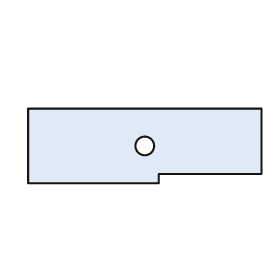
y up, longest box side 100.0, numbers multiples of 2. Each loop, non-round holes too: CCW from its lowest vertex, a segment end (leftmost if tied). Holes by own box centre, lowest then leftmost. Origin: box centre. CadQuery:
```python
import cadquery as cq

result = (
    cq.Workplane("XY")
    .moveTo(-50.0, -16.0)
    .lineTo(6.0, -16.0)
    .lineTo(6.0, -12.0)
    .lineTo(50.0, -12.0)
    .lineTo(50.0, 16.0)
    .lineTo(-50.0, 16.0)
    .close()
    .moveTo(0.0, 0.0)
    .circle(4.0)
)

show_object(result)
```